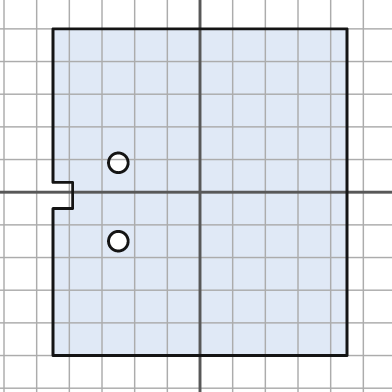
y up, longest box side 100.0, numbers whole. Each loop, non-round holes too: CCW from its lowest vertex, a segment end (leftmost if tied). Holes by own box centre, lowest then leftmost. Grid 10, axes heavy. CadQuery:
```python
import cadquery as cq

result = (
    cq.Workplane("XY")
    .moveTo(-45.0, -50.0)
    .lineTo(45.0, -50.0)
    .lineTo(45.0, 50.0)
    .lineTo(-45.0, 50.0)
    .lineTo(-45.0, 3.0)
    .lineTo(-39.0, 3.0)
    .lineTo(-39.0, -5.0)
    .lineTo(-45.0, -5.0)
    .close()
    .moveTo(-25.0, -15.0)
    .circle(3.0)
    .moveTo(-25.0, 9.0)
    .circle(3.0)
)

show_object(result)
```